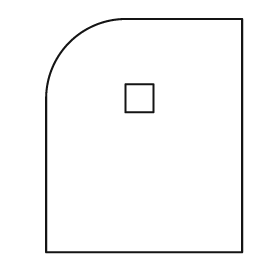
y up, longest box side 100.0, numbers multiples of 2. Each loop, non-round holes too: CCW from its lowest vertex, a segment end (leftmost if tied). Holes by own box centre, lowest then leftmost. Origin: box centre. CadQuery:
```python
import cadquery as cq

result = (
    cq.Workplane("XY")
    .moveTo(-42.0, -50.0)
    .lineTo(42.0, -50.0)
    .lineTo(42.0, 50.0)
    .lineTo(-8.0, 50.0)
    .threePointArc((-32.0, 40.0), (-42.0, 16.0))
    .close()
    .moveTo(-8.0, 10.0)
    .lineTo(4.0, 10.0)
    .lineTo(4.0, 22.0)
    .lineTo(-8.0, 22.0)
    .close()
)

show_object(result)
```